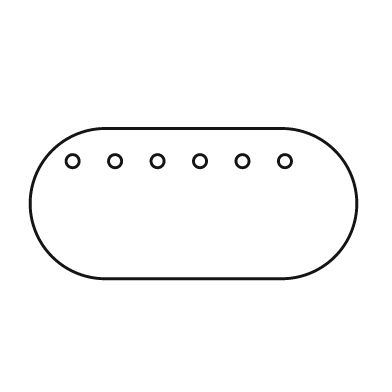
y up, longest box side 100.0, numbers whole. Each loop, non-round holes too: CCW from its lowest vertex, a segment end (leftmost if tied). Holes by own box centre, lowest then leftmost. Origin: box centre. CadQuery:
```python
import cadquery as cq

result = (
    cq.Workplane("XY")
    .moveTo(-27.0, -23.0)
    .lineTo(27.0, -23.0)
    .threePointArc((50.0, 0.0), (27.0, 23.0))
    .lineTo(-27.0, 23.0)
    .threePointArc((-50.0, 0.0), (-27.0, -23.0))
    .close()
    .moveTo(-37.0, 13.0)
    .circle(2.0)
    .moveTo(-24.0, 13.0)
    .circle(2.0)
    .moveTo(-11.0, 13.0)
    .circle(2.0)
    .moveTo(2.0, 13.0)
    .circle(2.0)
    .moveTo(15.0, 13.0)
    .circle(2.0)
    .moveTo(28.0, 13.0)
    .circle(2.0)
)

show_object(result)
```